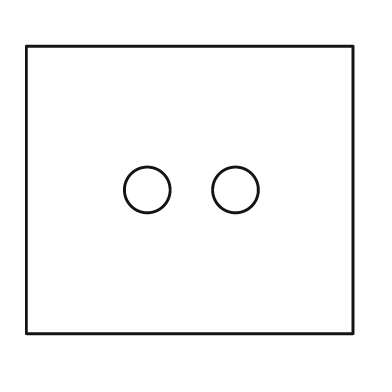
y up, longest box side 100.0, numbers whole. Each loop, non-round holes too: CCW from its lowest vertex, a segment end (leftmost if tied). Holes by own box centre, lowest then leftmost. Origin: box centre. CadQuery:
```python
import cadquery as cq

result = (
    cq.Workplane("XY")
    .moveTo(-50.0, -44.0)
    .lineTo(50.0, -44.0)
    .lineTo(50.0, 44.0)
    .lineTo(-50.0, 44.0)
    .close()
    .moveTo(-13.0, 0.0)
    .circle(7.0)
    .moveTo(14.0, 0.0)
    .circle(7.0)
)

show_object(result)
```